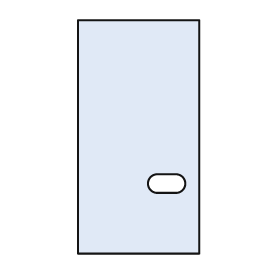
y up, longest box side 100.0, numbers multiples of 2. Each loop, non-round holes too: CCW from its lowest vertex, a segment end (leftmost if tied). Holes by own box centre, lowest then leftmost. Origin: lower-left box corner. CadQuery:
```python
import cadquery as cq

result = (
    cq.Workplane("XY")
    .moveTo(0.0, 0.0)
    .lineTo(52.0, 0.0)
    .lineTo(52.0, 100.0)
    .lineTo(0.0, 100.0)
    .close()
    .moveTo(34.0, 26.0)
    .lineTo(42.0, 26.0)
    .threePointArc((46.0, 30.0), (42.0, 34.0))
    .lineTo(34.0, 34.0)
    .threePointArc((30.0, 30.0), (34.0, 26.0))
    .close()
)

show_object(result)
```